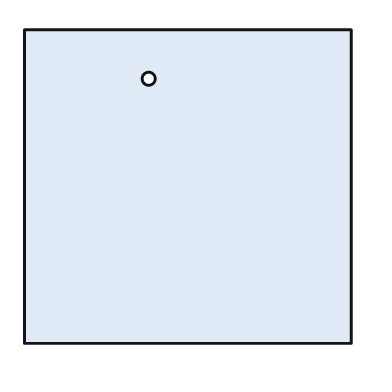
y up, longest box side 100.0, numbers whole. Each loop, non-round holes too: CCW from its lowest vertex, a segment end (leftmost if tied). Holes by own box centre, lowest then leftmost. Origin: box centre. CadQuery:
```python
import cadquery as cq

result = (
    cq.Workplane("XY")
    .moveTo(-50.0, -48.0)
    .lineTo(50.0, -48.0)
    .lineTo(50.0, 48.0)
    .lineTo(-50.0, 48.0)
    .close()
    .moveTo(-12.0, 33.0)
    .circle(2.0)
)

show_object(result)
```